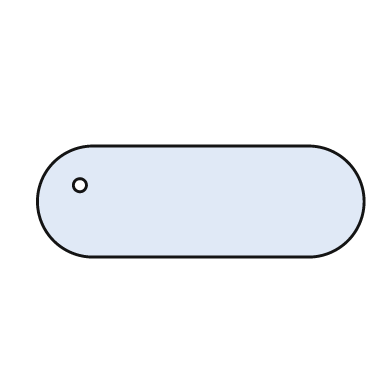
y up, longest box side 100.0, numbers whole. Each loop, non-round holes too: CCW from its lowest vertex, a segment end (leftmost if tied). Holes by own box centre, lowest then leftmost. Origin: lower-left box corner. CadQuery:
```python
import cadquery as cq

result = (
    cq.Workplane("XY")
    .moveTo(17.0, 0.0)
    .lineTo(83.0, 0.0)
    .threePointArc((100.0, 17.0), (83.0, 34.0))
    .lineTo(17.0, 34.0)
    .threePointArc((0.0, 17.0), (17.0, 0.0))
    .close()
    .moveTo(13.0, 22.0)
    .circle(2.0)
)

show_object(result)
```